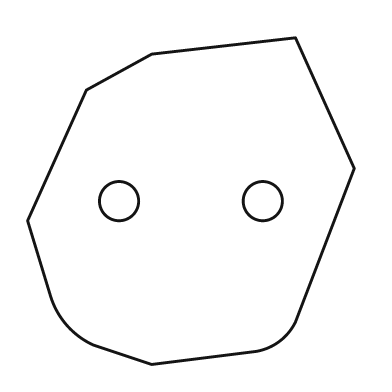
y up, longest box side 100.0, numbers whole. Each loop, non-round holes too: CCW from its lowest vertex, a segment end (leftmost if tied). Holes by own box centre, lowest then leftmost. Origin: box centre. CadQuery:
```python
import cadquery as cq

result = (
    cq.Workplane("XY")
    .moveTo(-12.0, -50.0)
    .lineTo(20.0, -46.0)
    .threePointArc((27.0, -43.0), (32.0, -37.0))
    .lineTo(50.0, 10.0)
    .lineTo(32.0, 50.0)
    .lineTo(-12.0, 45.0)
    .lineTo(-32.0, 34.0)
    .lineTo(-50.0, -6.0)
    .lineTo(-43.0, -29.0)
    .threePointArc((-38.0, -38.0), (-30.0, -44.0))
    .close()
    .moveTo(-22.0, 0.0)
    .circle(6.0)
    .moveTo(22.0, 0.0)
    .circle(6.0)
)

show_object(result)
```